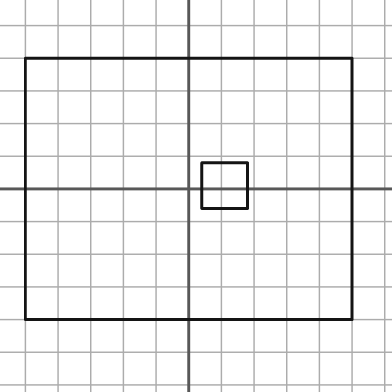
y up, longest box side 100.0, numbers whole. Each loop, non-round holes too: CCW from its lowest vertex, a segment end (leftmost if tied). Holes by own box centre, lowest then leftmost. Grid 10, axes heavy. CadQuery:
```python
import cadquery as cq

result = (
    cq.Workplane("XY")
    .moveTo(-50.0, -40.0)
    .lineTo(50.0, -40.0)
    .lineTo(50.0, 40.0)
    .lineTo(-50.0, 40.0)
    .close()
    .moveTo(4.0, -6.0)
    .lineTo(18.0, -6.0)
    .lineTo(18.0, 8.0)
    .lineTo(4.0, 8.0)
    .close()
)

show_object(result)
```